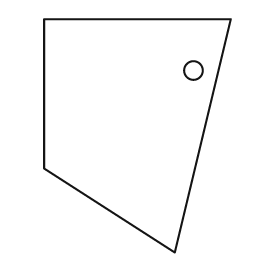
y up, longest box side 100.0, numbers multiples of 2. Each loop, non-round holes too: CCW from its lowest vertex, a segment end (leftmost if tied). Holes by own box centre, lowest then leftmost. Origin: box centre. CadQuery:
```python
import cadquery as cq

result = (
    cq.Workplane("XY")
    .moveTo(16.0, -50.0)
    .lineTo(40.0, 50.0)
    .lineTo(-40.0, 50.0)
    .lineTo(-40.0, -14.0)
    .close()
    .moveTo(24.0, 28.0)
    .circle(4.0)
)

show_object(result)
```